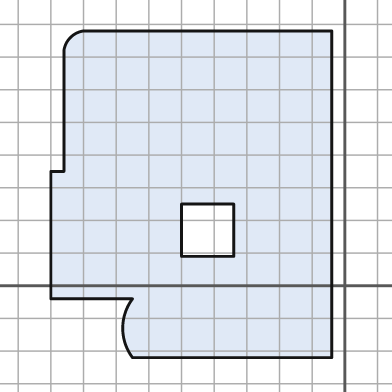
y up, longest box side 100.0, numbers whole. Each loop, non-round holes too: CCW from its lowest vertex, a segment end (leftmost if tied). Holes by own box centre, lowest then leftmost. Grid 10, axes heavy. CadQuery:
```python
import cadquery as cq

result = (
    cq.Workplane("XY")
    .moveTo(-65.0, -22.0)
    .lineTo(-4.0, -22.0)
    .lineTo(-4.0, 78.0)
    .lineTo(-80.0, 78.0)
    .threePointArc((-84.0, 76.0), (-86.0, 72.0))
    .lineTo(-86.0, 35.0)
    .lineTo(-90.0, 35.0)
    .lineTo(-90.0, -4.0)
    .lineTo(-65.0, -4.0)
    .threePointArc((-68.0, -13.0), (-65.0, -22.0))
    .close()
    .moveTo(-50.0, 9.0)
    .lineTo(-34.0, 9.0)
    .lineTo(-34.0, 25.0)
    .lineTo(-50.0, 25.0)
    .close()
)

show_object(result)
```